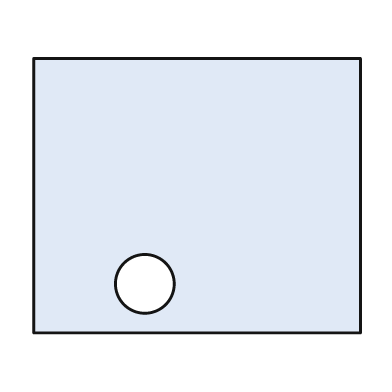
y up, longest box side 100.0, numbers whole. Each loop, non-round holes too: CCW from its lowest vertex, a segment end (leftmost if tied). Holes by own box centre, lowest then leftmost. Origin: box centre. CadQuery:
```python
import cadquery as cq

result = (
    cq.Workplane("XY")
    .moveTo(-50.0, -42.0)
    .lineTo(50.0, -42.0)
    .lineTo(50.0, 42.0)
    .lineTo(-50.0, 42.0)
    .close()
    .moveTo(-16.0, -27.0)
    .circle(9.0)
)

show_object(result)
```